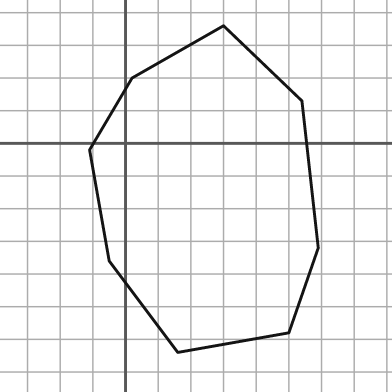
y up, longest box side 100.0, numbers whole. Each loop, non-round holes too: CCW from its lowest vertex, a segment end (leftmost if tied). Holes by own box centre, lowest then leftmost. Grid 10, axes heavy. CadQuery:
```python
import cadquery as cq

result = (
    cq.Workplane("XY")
    .moveTo(16.0, -64.0)
    .lineTo(50.0, -58.0)
    .lineTo(59.0, -32.0)
    .lineTo(54.0, 13.0)
    .lineTo(30.0, 36.0)
    .lineTo(2.0, 20.0)
    .lineTo(-11.0, -2.0)
    .lineTo(-5.0, -36.0)
    .close()
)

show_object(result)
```